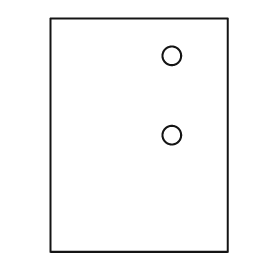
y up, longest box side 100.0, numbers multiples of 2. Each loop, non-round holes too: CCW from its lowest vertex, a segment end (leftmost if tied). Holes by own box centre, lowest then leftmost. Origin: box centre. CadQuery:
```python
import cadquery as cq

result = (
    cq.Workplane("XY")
    .moveTo(-38.0, -50.0)
    .lineTo(38.0, -50.0)
    .lineTo(38.0, 50.0)
    .lineTo(-38.0, 50.0)
    .close()
    .moveTo(14.0, 0.0)
    .circle(4.0)
    .moveTo(14.0, 34.0)
    .circle(4.0)
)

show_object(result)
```